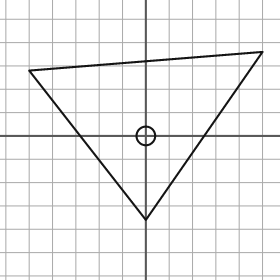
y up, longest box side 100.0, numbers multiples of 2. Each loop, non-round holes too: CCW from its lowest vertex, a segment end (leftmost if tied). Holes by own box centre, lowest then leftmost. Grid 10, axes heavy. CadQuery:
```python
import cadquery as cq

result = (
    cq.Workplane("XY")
    .moveTo(0.0, -36.0)
    .lineTo(50.0, 36.0)
    .lineTo(-50.0, 28.0)
    .close()
    .moveTo(0.0, 0.0)
    .circle(4.0)
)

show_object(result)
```